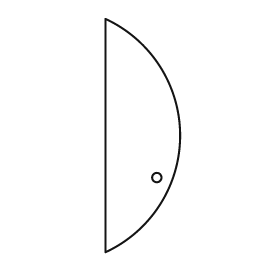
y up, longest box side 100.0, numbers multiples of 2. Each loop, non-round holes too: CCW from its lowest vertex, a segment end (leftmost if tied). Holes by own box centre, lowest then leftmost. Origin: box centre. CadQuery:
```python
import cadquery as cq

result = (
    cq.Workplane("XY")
    .moveTo(-16.0, -50.0)
    .threePointArc((16.0, 0.0), (-16.0, 50.0))
    .close()
    .moveTo(6.0, -18.0)
    .circle(2.0)
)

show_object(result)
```